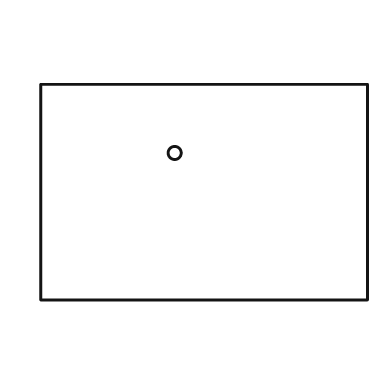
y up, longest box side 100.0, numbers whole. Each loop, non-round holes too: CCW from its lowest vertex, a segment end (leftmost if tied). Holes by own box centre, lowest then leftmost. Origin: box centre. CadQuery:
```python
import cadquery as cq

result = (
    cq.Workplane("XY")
    .moveTo(-50.0, -33.0)
    .lineTo(50.0, -33.0)
    .lineTo(50.0, 33.0)
    .lineTo(-50.0, 33.0)
    .close()
    .moveTo(-9.0, 12.0)
    .circle(2.0)
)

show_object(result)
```